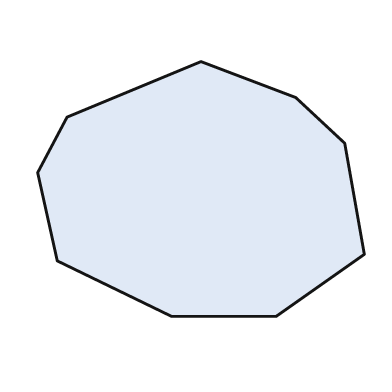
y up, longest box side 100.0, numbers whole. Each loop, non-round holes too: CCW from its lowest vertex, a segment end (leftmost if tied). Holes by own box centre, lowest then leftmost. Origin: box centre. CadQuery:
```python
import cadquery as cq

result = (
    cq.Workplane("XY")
    .moveTo(-9.0, -39.0)
    .lineTo(23.0, -39.0)
    .lineTo(50.0, -20.0)
    .lineTo(44.0, 14.0)
    .lineTo(29.0, 28.0)
    .lineTo(0.0, 39.0)
    .lineTo(-41.0, 22.0)
    .lineTo(-50.0, 5.0)
    .lineTo(-44.0, -22.0)
    .close()
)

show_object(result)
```